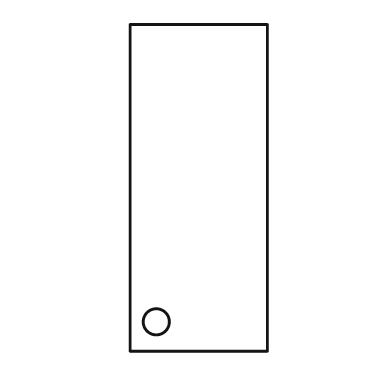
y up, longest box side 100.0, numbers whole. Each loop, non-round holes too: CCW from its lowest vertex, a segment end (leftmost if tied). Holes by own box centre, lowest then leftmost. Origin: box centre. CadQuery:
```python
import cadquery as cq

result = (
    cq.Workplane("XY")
    .moveTo(-21.0, -50.0)
    .lineTo(21.0, -50.0)
    .lineTo(21.0, 50.0)
    .lineTo(-21.0, 50.0)
    .close()
    .moveTo(-13.0, -41.0)
    .circle(4.0)
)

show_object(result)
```